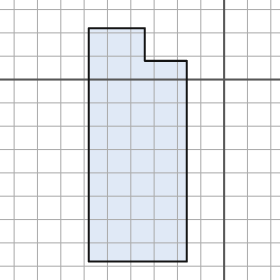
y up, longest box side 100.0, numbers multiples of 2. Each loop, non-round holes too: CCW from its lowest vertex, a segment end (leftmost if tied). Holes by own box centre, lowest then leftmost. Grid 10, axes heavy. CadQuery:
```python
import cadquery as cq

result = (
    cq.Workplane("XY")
    .moveTo(-58.0, -78.0)
    .lineTo(-16.0, -78.0)
    .lineTo(-16.0, 8.0)
    .lineTo(-34.0, 8.0)
    .lineTo(-34.0, 22.0)
    .lineTo(-58.0, 22.0)
    .close()
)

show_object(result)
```